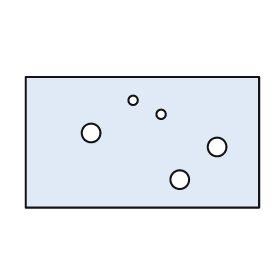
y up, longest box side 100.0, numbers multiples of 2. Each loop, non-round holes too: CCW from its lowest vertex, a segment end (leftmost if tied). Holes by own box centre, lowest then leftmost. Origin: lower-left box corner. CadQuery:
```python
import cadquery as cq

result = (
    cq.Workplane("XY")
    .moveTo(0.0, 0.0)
    .lineTo(100.0, 0.0)
    .lineTo(100.0, 56.0)
    .lineTo(0.0, 56.0)
    .close()
    .moveTo(66.0, 12.0)
    .circle(4.0)
    .moveTo(82.0, 26.0)
    .circle(4.0)
    .moveTo(28.0, 32.0)
    .circle(4.0)
    .moveTo(58.0, 40.0)
    .circle(2.0)
    .moveTo(46.0, 46.0)
    .circle(2.0)
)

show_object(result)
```